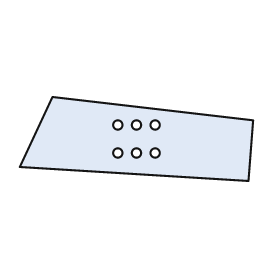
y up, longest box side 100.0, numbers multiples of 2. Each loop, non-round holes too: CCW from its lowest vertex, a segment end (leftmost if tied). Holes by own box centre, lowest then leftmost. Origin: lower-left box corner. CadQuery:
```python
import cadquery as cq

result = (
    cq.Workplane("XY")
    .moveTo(98.0, 0.0)
    .lineTo(100.0, 26.0)
    .lineTo(14.0, 36.0)
    .lineTo(0.0, 6.0)
    .close()
    .moveTo(42.0, 12.0)
    .circle(2.0)
    .moveTo(50.0, 12.0)
    .circle(2.0)
    .moveTo(58.0, 12.0)
    .circle(2.0)
    .moveTo(42.0, 24.0)
    .circle(2.0)
    .moveTo(50.0, 24.0)
    .circle(2.0)
    .moveTo(58.0, 24.0)
    .circle(2.0)
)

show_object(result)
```